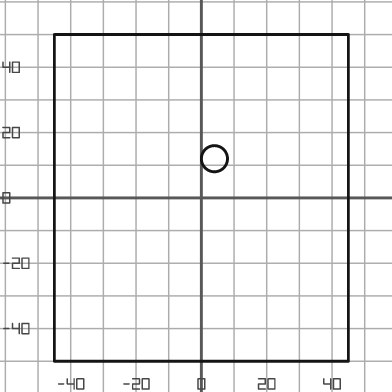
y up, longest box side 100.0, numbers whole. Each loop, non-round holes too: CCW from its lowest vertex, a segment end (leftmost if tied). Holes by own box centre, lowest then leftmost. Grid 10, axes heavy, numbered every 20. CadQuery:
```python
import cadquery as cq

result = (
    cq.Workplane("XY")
    .moveTo(-45.0, -50.0)
    .lineTo(45.0, -50.0)
    .lineTo(45.0, 50.0)
    .lineTo(-45.0, 50.0)
    .close()
    .moveTo(4.0, 12.0)
    .circle(4.0)
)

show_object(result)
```